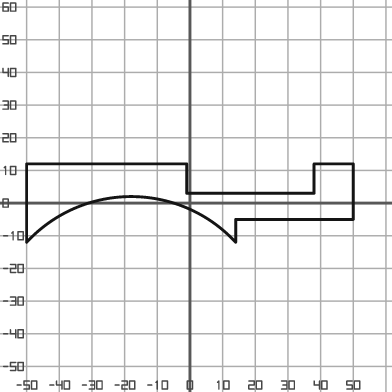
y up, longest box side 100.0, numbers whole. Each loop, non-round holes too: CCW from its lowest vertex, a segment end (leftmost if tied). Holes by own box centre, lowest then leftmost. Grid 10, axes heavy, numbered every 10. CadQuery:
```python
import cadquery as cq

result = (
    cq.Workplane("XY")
    .moveTo(-50.0, -12.0)
    .threePointArc((-18.0, 2.0), (14.0, -12.0))
    .lineTo(14.0, -5.0)
    .lineTo(50.0, -5.0)
    .lineTo(50.0, 12.0)
    .lineTo(38.0, 12.0)
    .lineTo(38.0, 3.0)
    .lineTo(-1.0, 3.0)
    .lineTo(-1.0, 12.0)
    .lineTo(-50.0, 12.0)
    .close()
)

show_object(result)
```